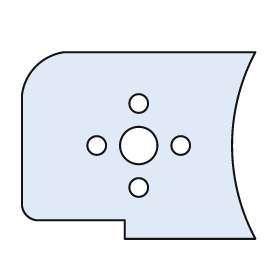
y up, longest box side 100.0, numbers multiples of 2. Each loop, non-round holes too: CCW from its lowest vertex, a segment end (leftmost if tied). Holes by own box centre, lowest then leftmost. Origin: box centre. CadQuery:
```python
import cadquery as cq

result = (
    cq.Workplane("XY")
    .moveTo(-6.0, -40.0)
    .lineTo(50.0, -40.0)
    .threePointArc((40.0, 0.0), (50.0, 40.0))
    .lineTo(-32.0, 40.0)
    .threePointArc((-44.0, 34.0), (-50.0, 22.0))
    .lineTo(-50.0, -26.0)
    .threePointArc((-48.0, -30.0), (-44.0, -32.0))
    .lineTo(-6.0, -32.0)
    .close()
    .moveTo(0.0, -18.0)
    .circle(4.0)
    .moveTo(-18.0, 0.0)
    .circle(4.0)
    .moveTo(0.0, 0.0)
    .circle(8.0)
    .moveTo(18.0, 0.0)
    .circle(4.0)
    .moveTo(0.0, 18.0)
    .circle(4.0)
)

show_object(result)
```